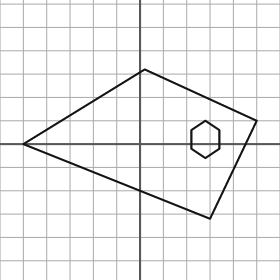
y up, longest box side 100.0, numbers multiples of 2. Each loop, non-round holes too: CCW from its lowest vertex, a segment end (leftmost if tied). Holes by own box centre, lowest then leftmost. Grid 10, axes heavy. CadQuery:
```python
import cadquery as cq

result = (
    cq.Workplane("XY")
    .moveTo(30.0, -32.0)
    .lineTo(50.0, 10.0)
    .lineTo(2.0, 32.0)
    .lineTo(-50.0, 0.0)
    .close()
    .moveTo(28.0, -6.0)
    .lineTo(34.0, -2.0)
    .lineTo(34.0, 6.0)
    .lineTo(28.0, 10.0)
    .lineTo(22.0, 6.0)
    .lineTo(22.0, -2.0)
    .close()
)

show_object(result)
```